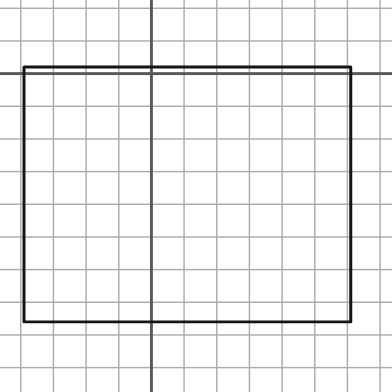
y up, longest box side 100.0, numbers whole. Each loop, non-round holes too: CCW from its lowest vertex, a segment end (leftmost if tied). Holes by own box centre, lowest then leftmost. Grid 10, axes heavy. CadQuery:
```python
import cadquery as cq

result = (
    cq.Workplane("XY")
    .moveTo(-39.0, -76.0)
    .lineTo(61.0, -76.0)
    .lineTo(61.0, 2.0)
    .lineTo(-39.0, 2.0)
    .close()
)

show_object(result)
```